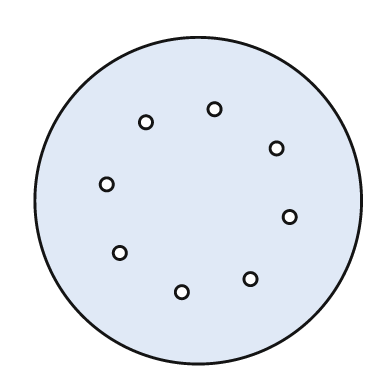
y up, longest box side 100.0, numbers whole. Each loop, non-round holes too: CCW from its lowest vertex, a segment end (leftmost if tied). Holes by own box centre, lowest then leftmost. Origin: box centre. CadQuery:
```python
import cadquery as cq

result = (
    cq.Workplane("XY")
    .moveTo(0.0, 0.0)
    .circle(50.0)
    .moveTo(-5.0, -28.0)
    .circle(2.0)
    .moveTo(16.0, -24.0)
    .circle(2.0)
    .moveTo(-24.0, -16.0)
    .circle(2.0)
    .moveTo(28.0, -5.0)
    .circle(2.0)
    .moveTo(-28.0, 5.0)
    .circle(2.0)
    .moveTo(24.0, 16.0)
    .circle(2.0)
    .moveTo(-16.0, 24.0)
    .circle(2.0)
    .moveTo(5.0, 28.0)
    .circle(2.0)
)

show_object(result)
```